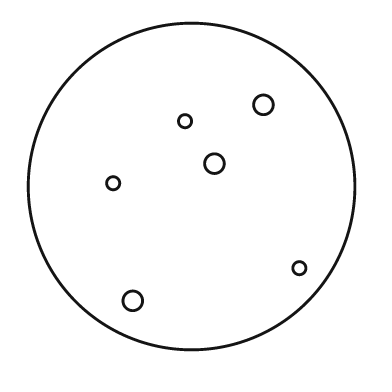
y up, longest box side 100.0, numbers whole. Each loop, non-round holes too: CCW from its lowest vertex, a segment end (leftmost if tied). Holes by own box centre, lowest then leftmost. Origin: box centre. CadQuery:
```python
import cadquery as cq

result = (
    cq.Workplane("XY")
    .moveTo(0.0, 0.0)
    .circle(50.0)
    .moveTo(-18.0, -35.0)
    .circle(3.0)
    .moveTo(33.0, -25.0)
    .circle(2.0)
    .moveTo(-24.0, 1.0)
    .circle(2.0)
    .moveTo(7.0, 7.0)
    .circle(3.0)
    .moveTo(-2.0, 20.0)
    .circle(2.0)
    .moveTo(22.0, 25.0)
    .circle(3.0)
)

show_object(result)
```